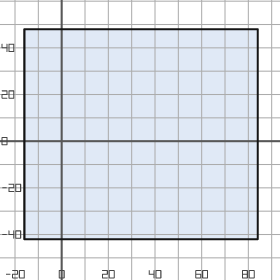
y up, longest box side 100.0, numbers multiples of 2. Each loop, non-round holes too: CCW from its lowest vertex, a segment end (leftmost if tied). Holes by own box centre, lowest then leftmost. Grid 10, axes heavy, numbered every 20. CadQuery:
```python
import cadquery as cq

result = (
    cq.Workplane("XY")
    .moveTo(-16.0, -42.0)
    .lineTo(84.0, -42.0)
    .lineTo(84.0, 48.0)
    .lineTo(-16.0, 48.0)
    .close()
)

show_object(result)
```